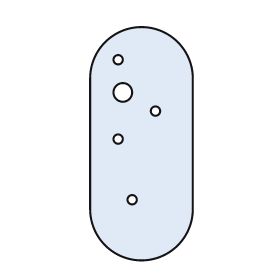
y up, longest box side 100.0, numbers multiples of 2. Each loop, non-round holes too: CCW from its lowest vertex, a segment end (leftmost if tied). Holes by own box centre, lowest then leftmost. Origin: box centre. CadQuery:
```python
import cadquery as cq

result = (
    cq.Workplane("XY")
    .moveTo(-22.0, -28.0)
    .threePointArc((0.0, -50.0), (22.0, -28.0))
    .lineTo(22.0, 28.0)
    .threePointArc((0.0, 50.0), (-22.0, 28.0))
    .close()
    .moveTo(-4.0, -24.0)
    .circle(2.0)
    .moveTo(-10.0, 2.0)
    .circle(2.0)
    .moveTo(6.0, 14.0)
    .circle(2.0)
    .moveTo(-8.0, 22.0)
    .circle(4.0)
    .moveTo(-10.0, 36.0)
    .circle(2.0)
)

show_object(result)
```